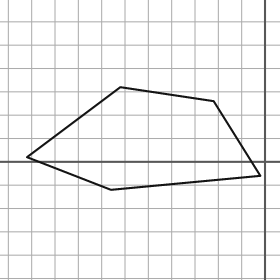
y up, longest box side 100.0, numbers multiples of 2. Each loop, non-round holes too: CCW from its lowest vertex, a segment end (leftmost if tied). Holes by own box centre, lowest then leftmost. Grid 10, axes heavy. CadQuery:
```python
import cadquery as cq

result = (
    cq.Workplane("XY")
    .moveTo(-66.0, -12.0)
    .lineTo(-2.0, -6.0)
    .lineTo(-22.0, 26.0)
    .lineTo(-62.0, 32.0)
    .lineTo(-102.0, 2.0)
    .close()
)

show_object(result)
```